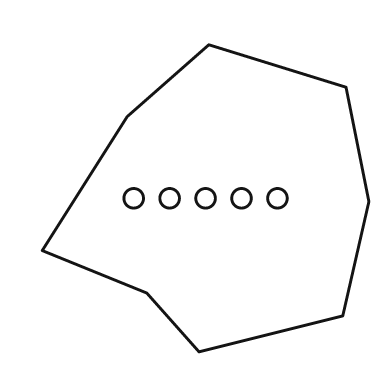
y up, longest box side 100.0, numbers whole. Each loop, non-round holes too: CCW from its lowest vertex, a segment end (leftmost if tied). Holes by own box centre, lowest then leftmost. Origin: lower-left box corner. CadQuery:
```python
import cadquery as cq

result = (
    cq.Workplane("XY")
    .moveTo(48.0, 0.0)
    .lineTo(92.0, 11.0)
    .lineTo(100.0, 46.0)
    .lineTo(93.0, 81.0)
    .lineTo(51.0, 94.0)
    .lineTo(26.0, 72.0)
    .lineTo(0.0, 31.0)
    .lineTo(32.0, 18.0)
    .close()
    .moveTo(28.0, 47.0)
    .circle(3.0)
    .moveTo(39.0, 47.0)
    .circle(3.0)
    .moveTo(50.0, 47.0)
    .circle(3.0)
    .moveTo(61.0, 47.0)
    .circle(3.0)
    .moveTo(72.0, 47.0)
    .circle(3.0)
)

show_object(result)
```